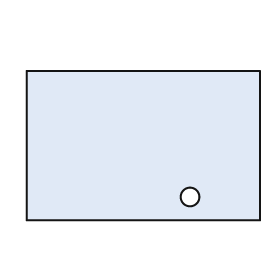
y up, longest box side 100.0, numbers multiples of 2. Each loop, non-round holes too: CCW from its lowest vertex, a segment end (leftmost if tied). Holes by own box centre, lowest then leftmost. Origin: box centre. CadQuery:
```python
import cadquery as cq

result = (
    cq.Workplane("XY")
    .moveTo(-50.0, -32.0)
    .lineTo(50.0, -32.0)
    .lineTo(50.0, 32.0)
    .lineTo(-50.0, 32.0)
    .close()
    .moveTo(20.0, -22.0)
    .circle(4.0)
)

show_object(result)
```